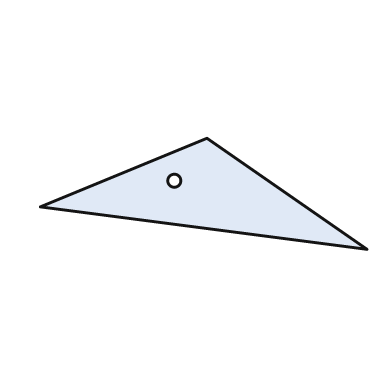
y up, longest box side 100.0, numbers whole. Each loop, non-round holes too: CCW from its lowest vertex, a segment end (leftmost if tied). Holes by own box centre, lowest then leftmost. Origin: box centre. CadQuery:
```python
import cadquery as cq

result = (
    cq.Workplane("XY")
    .moveTo(50.0, -17.0)
    .lineTo(1.0, 17.0)
    .lineTo(-50.0, -4.0)
    .close()
    .moveTo(-9.0, 4.0)
    .circle(2.0)
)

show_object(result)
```